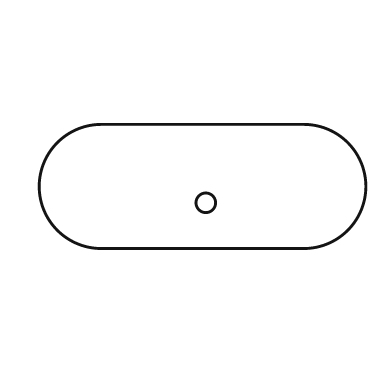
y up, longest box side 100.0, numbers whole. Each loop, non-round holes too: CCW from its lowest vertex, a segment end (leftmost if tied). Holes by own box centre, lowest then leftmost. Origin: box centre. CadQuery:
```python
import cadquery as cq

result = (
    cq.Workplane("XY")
    .moveTo(-31.0, -19.0)
    .lineTo(31.0, -19.0)
    .threePointArc((50.0, 0.0), (31.0, 19.0))
    .lineTo(-31.0, 19.0)
    .threePointArc((-50.0, 0.0), (-31.0, -19.0))
    .close()
    .moveTo(1.0, -5.0)
    .circle(3.0)
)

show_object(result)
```